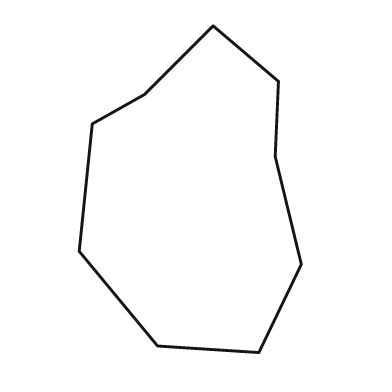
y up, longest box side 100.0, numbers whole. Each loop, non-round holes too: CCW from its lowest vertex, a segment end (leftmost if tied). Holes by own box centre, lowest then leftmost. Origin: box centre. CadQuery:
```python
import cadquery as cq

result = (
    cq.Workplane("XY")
    .moveTo(21.0, -50.0)
    .lineTo(34.0, -23.0)
    .lineTo(26.0, 10.0)
    .lineTo(27.0, 33.0)
    .lineTo(7.0, 50.0)
    .lineTo(-14.0, 29.0)
    .lineTo(-30.0, 20.0)
    .lineTo(-34.0, -19.0)
    .lineTo(-10.0, -48.0)
    .close()
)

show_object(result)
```